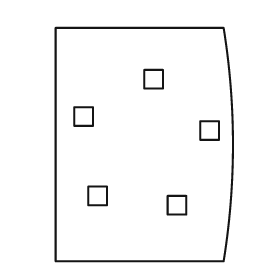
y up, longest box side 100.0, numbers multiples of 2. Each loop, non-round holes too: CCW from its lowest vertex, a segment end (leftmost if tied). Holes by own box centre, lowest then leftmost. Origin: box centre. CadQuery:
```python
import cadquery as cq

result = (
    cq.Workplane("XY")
    .moveTo(-38.0, -50.0)
    .lineTo(34.0, -50.0)
    .threePointArc((38.0, 0.0), (34.0, 50.0))
    .lineTo(-38.0, 50.0)
    .close()
    .moveTo(10.0, -30.0)
    .lineTo(18.0, -30.0)
    .lineTo(18.0, -22.0)
    .lineTo(10.0, -22.0)
    .close()
    .moveTo(-24.0, -26.0)
    .lineTo(-16.0, -26.0)
    .lineTo(-16.0, -18.0)
    .lineTo(-24.0, -18.0)
    .close()
    .moveTo(24.0, 2.0)
    .lineTo(32.0, 2.0)
    .lineTo(32.0, 10.0)
    .lineTo(24.0, 10.0)
    .close()
    .moveTo(-30.0, 8.0)
    .lineTo(-22.0, 8.0)
    .lineTo(-22.0, 16.0)
    .lineTo(-30.0, 16.0)
    .close()
    .moveTo(0.0, 24.0)
    .lineTo(8.0, 24.0)
    .lineTo(8.0, 32.0)
    .lineTo(0.0, 32.0)
    .close()
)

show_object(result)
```